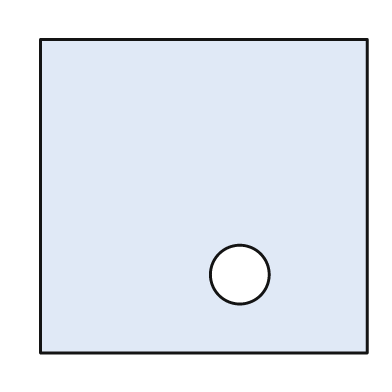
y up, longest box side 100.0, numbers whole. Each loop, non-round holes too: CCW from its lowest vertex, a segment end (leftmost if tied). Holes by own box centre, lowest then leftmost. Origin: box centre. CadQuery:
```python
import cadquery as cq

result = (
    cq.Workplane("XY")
    .moveTo(-50.0, -48.0)
    .lineTo(50.0, -48.0)
    .lineTo(50.0, 48.0)
    .lineTo(-50.0, 48.0)
    .close()
    .moveTo(11.0, -24.0)
    .circle(9.0)
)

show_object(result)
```